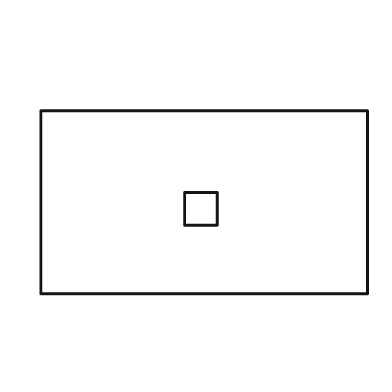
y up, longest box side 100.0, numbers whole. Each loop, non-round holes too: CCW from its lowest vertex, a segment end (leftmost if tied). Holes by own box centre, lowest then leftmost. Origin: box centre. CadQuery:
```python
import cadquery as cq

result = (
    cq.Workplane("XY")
    .moveTo(-50.0, -28.0)
    .lineTo(50.0, -28.0)
    .lineTo(50.0, 28.0)
    .lineTo(-50.0, 28.0)
    .close()
    .moveTo(-6.0, -7.0)
    .lineTo(4.0, -7.0)
    .lineTo(4.0, 3.0)
    .lineTo(-6.0, 3.0)
    .close()
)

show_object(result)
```